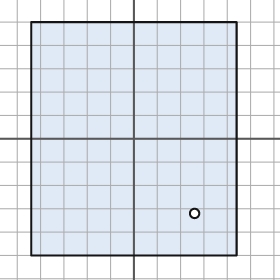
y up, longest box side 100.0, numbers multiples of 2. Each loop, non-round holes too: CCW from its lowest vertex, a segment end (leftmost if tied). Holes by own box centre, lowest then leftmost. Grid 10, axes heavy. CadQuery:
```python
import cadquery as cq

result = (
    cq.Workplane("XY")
    .moveTo(-44.0, -50.0)
    .lineTo(44.0, -50.0)
    .lineTo(44.0, 50.0)
    .lineTo(-44.0, 50.0)
    .close()
    .moveTo(26.0, -32.0)
    .circle(2.0)
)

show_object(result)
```